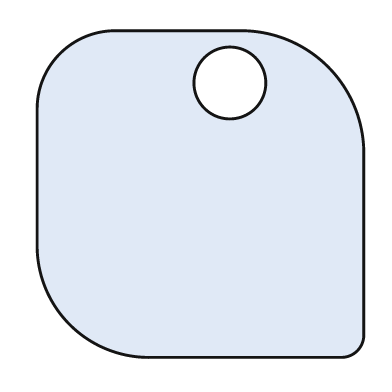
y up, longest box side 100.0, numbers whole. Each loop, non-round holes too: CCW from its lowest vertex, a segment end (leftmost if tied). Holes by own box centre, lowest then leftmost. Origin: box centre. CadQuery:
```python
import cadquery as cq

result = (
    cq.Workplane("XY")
    .moveTo(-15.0, -50.0)
    .lineTo(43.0, -50.0)
    .threePointArc((48.0, -48.0), (50.0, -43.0))
    .lineTo(50.0, 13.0)
    .threePointArc((39.0, 39.0), (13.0, 50.0))
    .lineTo(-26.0, 50.0)
    .threePointArc((-43.0, 43.0), (-50.0, 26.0))
    .lineTo(-50.0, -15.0)
    .threePointArc((-40.0, -40.0), (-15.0, -50.0))
    .close()
    .moveTo(9.0, 34.0)
    .circle(11.0)
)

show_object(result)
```